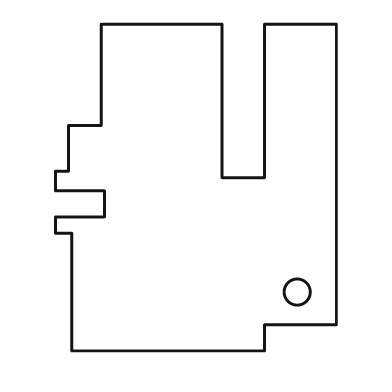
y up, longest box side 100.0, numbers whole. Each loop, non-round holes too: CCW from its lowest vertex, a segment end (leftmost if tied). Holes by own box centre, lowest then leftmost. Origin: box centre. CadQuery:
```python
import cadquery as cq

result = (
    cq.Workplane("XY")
    .moveTo(-38.0, -50.0)
    .lineTo(21.0, -50.0)
    .lineTo(21.0, -42.0)
    .lineTo(43.0, -42.0)
    .lineTo(43.0, 50.0)
    .lineTo(21.0, 50.0)
    .lineTo(21.0, 3.0)
    .lineTo(8.0, 3.0)
    .lineTo(8.0, 50.0)
    .lineTo(-29.0, 50.0)
    .lineTo(-29.0, 19.0)
    .lineTo(-39.0, 19.0)
    .lineTo(-39.0, 5.0)
    .lineTo(-43.0, 5.0)
    .lineTo(-43.0, -1.0)
    .lineTo(-28.0, -1.0)
    .lineTo(-28.0, -9.0)
    .lineTo(-43.0, -9.0)
    .lineTo(-43.0, -14.0)
    .lineTo(-38.0, -14.0)
    .close()
    .moveTo(31.0, -32.0)
    .circle(4.0)
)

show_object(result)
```